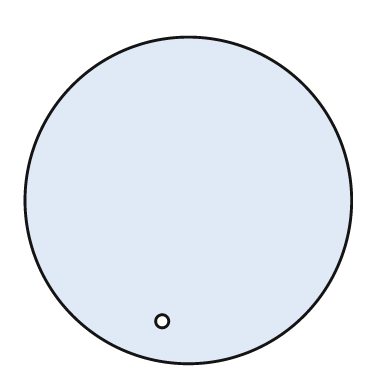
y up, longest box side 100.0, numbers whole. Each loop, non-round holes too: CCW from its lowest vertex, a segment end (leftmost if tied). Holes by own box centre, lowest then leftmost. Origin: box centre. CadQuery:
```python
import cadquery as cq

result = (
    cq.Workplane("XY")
    .moveTo(0.0, 0.0)
    .circle(50.0)
    .moveTo(-8.0, -37.0)
    .circle(2.0)
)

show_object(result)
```